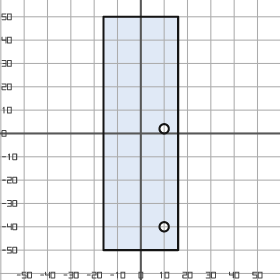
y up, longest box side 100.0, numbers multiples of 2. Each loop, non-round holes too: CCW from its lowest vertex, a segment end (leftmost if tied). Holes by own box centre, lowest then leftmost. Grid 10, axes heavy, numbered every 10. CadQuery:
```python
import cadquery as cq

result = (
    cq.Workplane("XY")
    .moveTo(-16.0, -50.0)
    .lineTo(16.0, -50.0)
    .lineTo(16.0, 50.0)
    .lineTo(-16.0, 50.0)
    .close()
    .moveTo(10.0, -40.0)
    .circle(2.0)
    .moveTo(10.0, 2.0)
    .circle(2.0)
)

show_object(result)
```